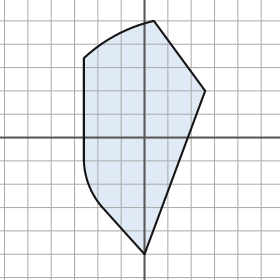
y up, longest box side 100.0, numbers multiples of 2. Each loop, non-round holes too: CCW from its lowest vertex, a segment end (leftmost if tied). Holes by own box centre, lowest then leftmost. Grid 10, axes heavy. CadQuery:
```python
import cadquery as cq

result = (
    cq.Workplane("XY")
    .moveTo(0.0, -50.0)
    .lineTo(26.0, 20.0)
    .lineTo(4.0, 50.0)
    .threePointArc((-12.0, 44.0), (-26.0, 34.0))
    .lineTo(-26.0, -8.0)
    .threePointArc((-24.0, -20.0), (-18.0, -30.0))
    .close()
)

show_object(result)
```